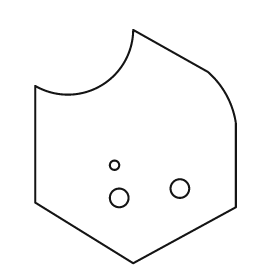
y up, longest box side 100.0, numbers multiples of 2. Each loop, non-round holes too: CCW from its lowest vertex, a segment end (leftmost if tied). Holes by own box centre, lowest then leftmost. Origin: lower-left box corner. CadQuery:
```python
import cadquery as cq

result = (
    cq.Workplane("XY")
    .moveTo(42.0, 0.0)
    .lineTo(86.0, 24.0)
    .lineTo(86.0, 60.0)
    .threePointArc((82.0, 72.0), (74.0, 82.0))
    .lineTo(42.0, 100.0)
    .threePointArc((28.0, 76.0), (0.0, 76.0))
    .lineTo(0.0, 26.0)
    .close()
    .moveTo(36.0, 28.0)
    .circle(4.0)
    .moveTo(62.0, 32.0)
    .circle(4.0)
    .moveTo(34.0, 42.0)
    .circle(2.0)
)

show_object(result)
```